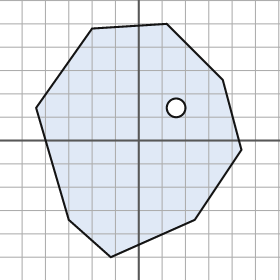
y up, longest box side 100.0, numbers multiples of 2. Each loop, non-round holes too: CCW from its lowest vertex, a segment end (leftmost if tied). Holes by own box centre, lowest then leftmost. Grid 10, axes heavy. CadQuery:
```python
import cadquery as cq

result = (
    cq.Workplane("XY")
    .moveTo(-12.0, -50.0)
    .lineTo(24.0, -34.0)
    .lineTo(44.0, -4.0)
    .lineTo(36.0, 26.0)
    .lineTo(12.0, 50.0)
    .lineTo(-20.0, 48.0)
    .lineTo(-44.0, 14.0)
    .lineTo(-30.0, -34.0)
    .close()
    .moveTo(16.0, 14.0)
    .circle(4.0)
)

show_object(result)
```